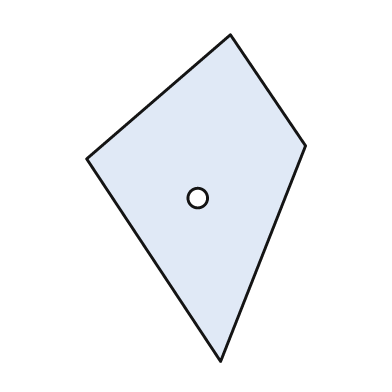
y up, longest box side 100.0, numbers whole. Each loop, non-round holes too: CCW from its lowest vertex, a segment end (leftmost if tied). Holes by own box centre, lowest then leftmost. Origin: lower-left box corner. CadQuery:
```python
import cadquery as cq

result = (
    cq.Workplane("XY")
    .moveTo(41.0, 0.0)
    .lineTo(67.0, 66.0)
    .lineTo(44.0, 100.0)
    .lineTo(0.0, 62.0)
    .close()
    .moveTo(34.0, 50.0)
    .circle(3.0)
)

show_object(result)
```